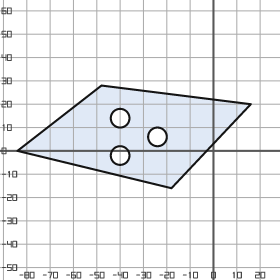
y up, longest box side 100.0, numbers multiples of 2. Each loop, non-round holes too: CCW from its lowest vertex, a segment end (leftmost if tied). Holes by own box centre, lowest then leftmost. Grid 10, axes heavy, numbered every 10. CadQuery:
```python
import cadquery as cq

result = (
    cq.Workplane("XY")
    .moveTo(-18.0, -16.0)
    .lineTo(16.0, 20.0)
    .lineTo(-48.0, 28.0)
    .lineTo(-84.0, 0.0)
    .close()
    .moveTo(-40.0, -2.0)
    .circle(4.0)
    .moveTo(-24.0, 6.0)
    .circle(4.0)
    .moveTo(-40.0, 14.0)
    .circle(4.0)
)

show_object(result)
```